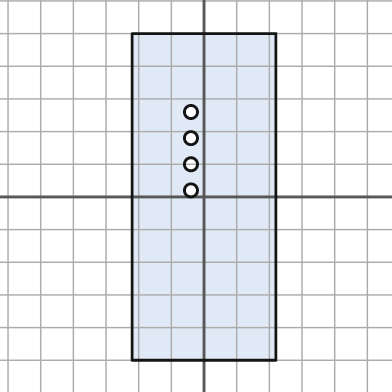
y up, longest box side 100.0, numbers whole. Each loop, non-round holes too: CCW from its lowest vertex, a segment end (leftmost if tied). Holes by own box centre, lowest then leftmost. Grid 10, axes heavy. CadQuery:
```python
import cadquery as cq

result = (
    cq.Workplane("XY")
    .moveTo(-22.0, -50.0)
    .lineTo(22.0, -50.0)
    .lineTo(22.0, 50.0)
    .lineTo(-22.0, 50.0)
    .close()
    .moveTo(-4.0, 2.0)
    .circle(2.0)
    .moveTo(-4.0, 10.0)
    .circle(2.0)
    .moveTo(-4.0, 18.0)
    .circle(2.0)
    .moveTo(-4.0, 26.0)
    .circle(2.0)
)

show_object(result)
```